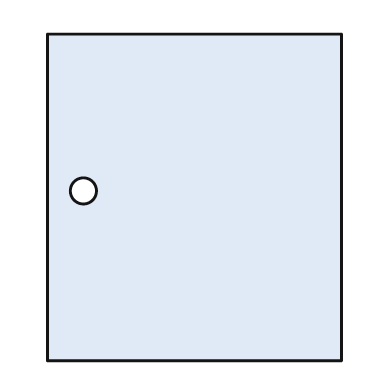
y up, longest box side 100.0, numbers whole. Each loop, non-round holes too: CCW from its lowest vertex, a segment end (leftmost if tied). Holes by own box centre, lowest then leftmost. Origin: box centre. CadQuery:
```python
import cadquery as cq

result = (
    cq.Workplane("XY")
    .moveTo(-45.0, -50.0)
    .lineTo(45.0, -50.0)
    .lineTo(45.0, 50.0)
    .lineTo(-45.0, 50.0)
    .close()
    .moveTo(-34.0, 2.0)
    .circle(4.0)
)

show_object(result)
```